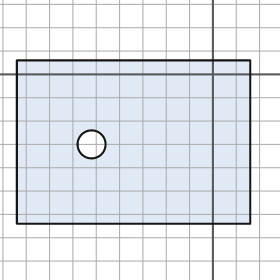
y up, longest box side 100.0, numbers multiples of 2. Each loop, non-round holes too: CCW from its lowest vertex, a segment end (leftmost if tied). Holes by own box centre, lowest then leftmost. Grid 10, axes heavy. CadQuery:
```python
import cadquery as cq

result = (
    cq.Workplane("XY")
    .moveTo(-84.0, -64.0)
    .lineTo(16.0, -64.0)
    .lineTo(16.0, 6.0)
    .lineTo(-84.0, 6.0)
    .close()
    .moveTo(-52.0, -30.0)
    .circle(6.0)
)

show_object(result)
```